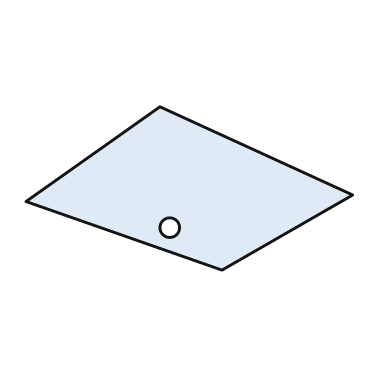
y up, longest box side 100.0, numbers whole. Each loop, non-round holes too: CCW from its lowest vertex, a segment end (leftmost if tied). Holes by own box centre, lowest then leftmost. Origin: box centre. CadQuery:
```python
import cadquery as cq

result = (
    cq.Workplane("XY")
    .moveTo(10.0, -25.0)
    .lineTo(50.0, -2.0)
    .lineTo(-9.0, 25.0)
    .lineTo(-50.0, -4.0)
    .close()
    .moveTo(-6.0, -12.0)
    .circle(3.0)
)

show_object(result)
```